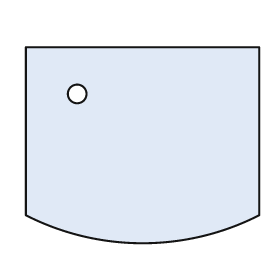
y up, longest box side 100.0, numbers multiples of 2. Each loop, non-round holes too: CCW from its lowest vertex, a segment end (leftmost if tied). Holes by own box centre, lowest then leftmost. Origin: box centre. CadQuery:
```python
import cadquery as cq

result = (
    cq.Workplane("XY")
    .moveTo(-50.0, -30.0)
    .threePointArc((0.0, -42.0), (50.0, -30.0))
    .lineTo(50.0, 42.0)
    .lineTo(-50.0, 42.0)
    .close()
    .moveTo(-28.0, 22.0)
    .circle(4.0)
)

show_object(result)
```